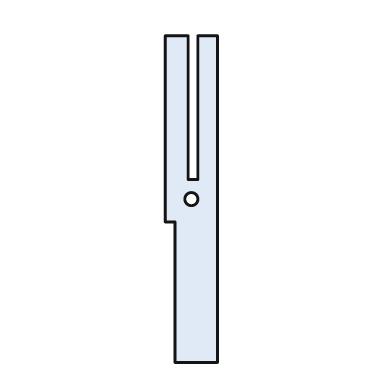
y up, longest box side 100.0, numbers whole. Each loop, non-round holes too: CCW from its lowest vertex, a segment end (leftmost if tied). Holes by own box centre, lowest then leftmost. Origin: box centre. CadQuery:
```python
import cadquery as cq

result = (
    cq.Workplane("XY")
    .moveTo(-5.0, -50.0)
    .lineTo(8.0, -50.0)
    .lineTo(8.0, 50.0)
    .lineTo(2.0, 50.0)
    .lineTo(2.0, 6.0)
    .lineTo(-1.0, 6.0)
    .lineTo(-1.0, 50.0)
    .lineTo(-8.0, 50.0)
    .lineTo(-8.0, -7.0)
    .lineTo(-5.0, -7.0)
    .close()
    .moveTo(0.0, 0.0)
    .circle(2.0)
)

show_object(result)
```